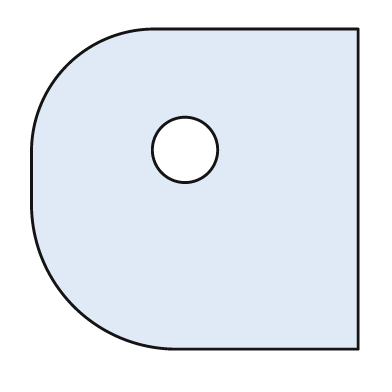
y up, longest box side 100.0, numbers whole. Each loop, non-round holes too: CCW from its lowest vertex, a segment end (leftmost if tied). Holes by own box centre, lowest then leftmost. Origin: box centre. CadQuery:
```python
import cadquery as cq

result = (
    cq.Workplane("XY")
    .moveTo(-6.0, -49.0)
    .lineTo(50.0, -49.0)
    .lineTo(50.0, 49.0)
    .lineTo(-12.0, 49.0)
    .threePointArc((-39.0, 38.0), (-50.0, 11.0))
    .lineTo(-50.0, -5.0)
    .threePointArc((-37.0, -36.0), (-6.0, -49.0))
    .close()
    .moveTo(-3.0, 12.0)
    .circle(10.0)
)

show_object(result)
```